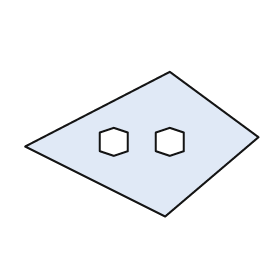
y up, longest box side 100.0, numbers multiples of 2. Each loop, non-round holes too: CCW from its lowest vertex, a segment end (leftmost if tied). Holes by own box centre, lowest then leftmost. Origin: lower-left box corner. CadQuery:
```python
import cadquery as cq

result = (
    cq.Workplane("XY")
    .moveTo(60.0, 0.0)
    .lineTo(100.0, 34.0)
    .lineTo(62.0, 62.0)
    .lineTo(0.0, 30.0)
    .close()
    .moveTo(38.0, 26.0)
    .lineTo(44.0, 28.0)
    .lineTo(44.0, 36.0)
    .lineTo(38.0, 38.0)
    .lineTo(32.0, 36.0)
    .lineTo(32.0, 28.0)
    .close()
    .moveTo(62.0, 26.0)
    .lineTo(68.0, 28.0)
    .lineTo(68.0, 36.0)
    .lineTo(62.0, 38.0)
    .lineTo(56.0, 36.0)
    .lineTo(56.0, 28.0)
    .close()
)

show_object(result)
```